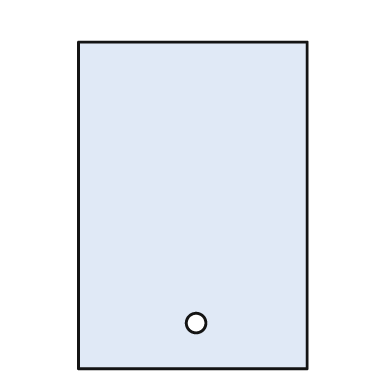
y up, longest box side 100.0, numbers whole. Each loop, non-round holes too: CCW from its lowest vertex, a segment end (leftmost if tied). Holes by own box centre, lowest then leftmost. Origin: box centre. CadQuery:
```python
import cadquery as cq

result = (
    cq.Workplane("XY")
    .moveTo(-35.0, -50.0)
    .lineTo(35.0, -50.0)
    .lineTo(35.0, 50.0)
    .lineTo(-35.0, 50.0)
    .close()
    .moveTo(1.0, -36.0)
    .circle(3.0)
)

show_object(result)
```